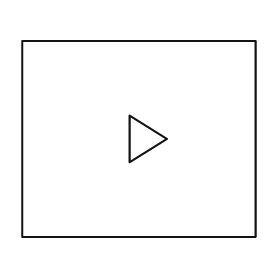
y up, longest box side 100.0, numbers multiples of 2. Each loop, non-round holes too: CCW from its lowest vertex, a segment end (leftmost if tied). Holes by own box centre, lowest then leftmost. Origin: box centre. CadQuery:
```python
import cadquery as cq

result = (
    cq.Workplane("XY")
    .moveTo(-50.0, -42.0)
    .lineTo(50.0, -42.0)
    .lineTo(50.0, 42.0)
    .lineTo(-50.0, 42.0)
    .close()
    .moveTo(-4.0, -10.0)
    .lineTo(12.0, 0.0)
    .lineTo(-4.0, 10.0)
    .close()
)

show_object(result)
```